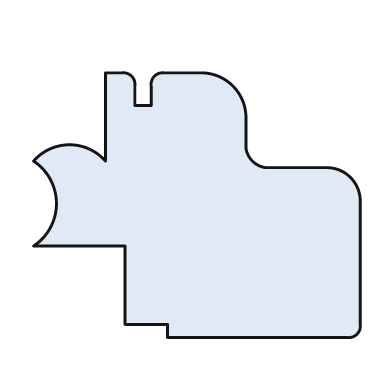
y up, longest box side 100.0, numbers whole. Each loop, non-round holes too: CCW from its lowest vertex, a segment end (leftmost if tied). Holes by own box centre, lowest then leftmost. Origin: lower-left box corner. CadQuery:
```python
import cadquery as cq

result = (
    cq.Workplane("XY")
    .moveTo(41.0, 0.0)
    .lineTo(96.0, 0.0)
    .threePointArc((99.0, 1.0), (100.0, 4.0))
    .lineTo(100.0, 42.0)
    .threePointArc((97.0, 49.0), (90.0, 52.0))
    .lineTo(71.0, 52.0)
    .threePointArc((67.0, 54.0), (65.0, 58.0))
    .lineTo(65.0, 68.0)
    .threePointArc((61.0, 77.0), (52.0, 81.0))
    .lineTo(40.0, 81.0)
    .threePointArc((37.0, 80.0), (36.0, 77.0))
    .lineTo(36.0, 71.0)
    .lineTo(31.0, 71.0)
    .lineTo(31.0, 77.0)
    .threePointArc((30.0, 80.0), (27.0, 81.0))
    .lineTo(22.0, 81.0)
    .lineTo(22.0, 54.0)
    .threePointArc((11.0, 59.0), (0.0, 54.0))
    .threePointArc((7.0, 41.0), (0.0, 28.0))
    .lineTo(28.0, 28.0)
    .lineTo(28.0, 4.0)
    .lineTo(41.0, 4.0)
    .close()
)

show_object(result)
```